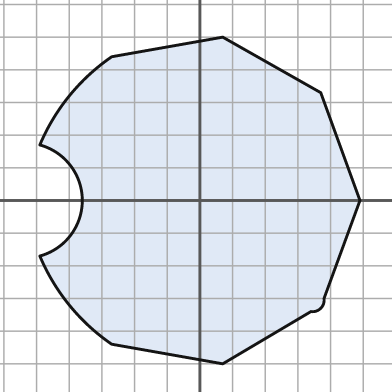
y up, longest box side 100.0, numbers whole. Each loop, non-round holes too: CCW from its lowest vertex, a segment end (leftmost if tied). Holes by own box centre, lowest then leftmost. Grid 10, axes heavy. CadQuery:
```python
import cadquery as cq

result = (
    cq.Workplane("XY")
    .moveTo(7.0, -50.0)
    .lineTo(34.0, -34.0)
    .threePointArc((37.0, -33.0), (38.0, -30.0))
    .lineTo(49.0, 0.0)
    .lineTo(37.0, 33.0)
    .lineTo(7.0, 50.0)
    .lineTo(-27.0, 44.0)
    .threePointArc((-40.0, 32.0), (-49.0, 17.0))
    .threePointArc((-36.0, 0.0), (-49.0, -17.0))
    .threePointArc((-40.0, -32.0), (-27.0, -44.0))
    .close()
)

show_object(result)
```